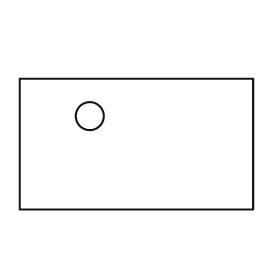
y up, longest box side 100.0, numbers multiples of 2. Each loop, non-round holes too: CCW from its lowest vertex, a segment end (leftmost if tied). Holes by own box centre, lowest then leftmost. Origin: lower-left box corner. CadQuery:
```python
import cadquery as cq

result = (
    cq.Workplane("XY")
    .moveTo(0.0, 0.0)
    .lineTo(100.0, 0.0)
    .lineTo(100.0, 56.0)
    .lineTo(0.0, 56.0)
    .close()
    .moveTo(30.0, 40.0)
    .circle(6.0)
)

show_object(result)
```